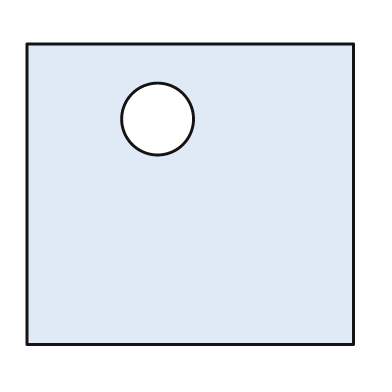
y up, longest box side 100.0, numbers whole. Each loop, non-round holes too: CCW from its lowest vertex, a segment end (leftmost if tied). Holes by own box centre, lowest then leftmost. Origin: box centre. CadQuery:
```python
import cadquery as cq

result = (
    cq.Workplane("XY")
    .moveTo(-50.0, -46.0)
    .lineTo(50.0, -46.0)
    .lineTo(50.0, 46.0)
    .lineTo(-50.0, 46.0)
    .close()
    .moveTo(-10.0, 23.0)
    .circle(11.0)
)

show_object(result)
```